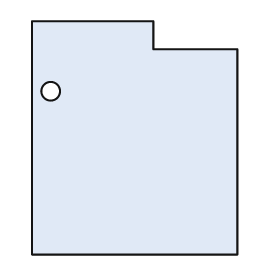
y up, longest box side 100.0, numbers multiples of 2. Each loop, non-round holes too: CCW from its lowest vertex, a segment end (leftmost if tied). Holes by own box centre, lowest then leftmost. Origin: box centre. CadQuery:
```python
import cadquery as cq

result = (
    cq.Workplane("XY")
    .moveTo(-44.0, -50.0)
    .lineTo(44.0, -50.0)
    .lineTo(44.0, 38.0)
    .lineTo(8.0, 38.0)
    .lineTo(8.0, 50.0)
    .lineTo(-44.0, 50.0)
    .close()
    .moveTo(-36.0, 20.0)
    .circle(4.0)
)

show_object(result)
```